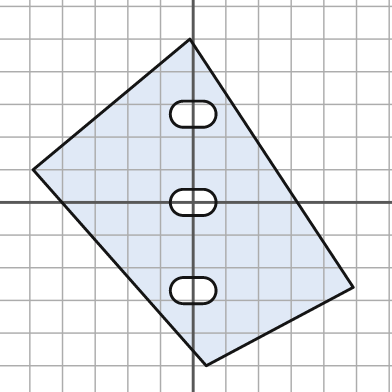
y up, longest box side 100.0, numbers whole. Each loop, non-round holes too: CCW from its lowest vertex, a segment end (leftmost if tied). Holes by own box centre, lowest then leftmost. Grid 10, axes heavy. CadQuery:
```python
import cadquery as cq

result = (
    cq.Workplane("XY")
    .moveTo(4.0, -50.0)
    .lineTo(49.0, -26.0)
    .lineTo(-1.0, 50.0)
    .lineTo(-49.0, 10.0)
    .close()
    .moveTo(-3.0, -31.0)
    .lineTo(3.0, -31.0)
    .threePointArc((7.0, -27.0), (3.0, -23.0))
    .lineTo(-3.0, -23.0)
    .threePointArc((-7.0, -27.0), (-3.0, -31.0))
    .close()
    .moveTo(-3.0, -4.0)
    .lineTo(3.0, -4.0)
    .threePointArc((7.0, 0.0), (3.0, 4.0))
    .lineTo(-3.0, 4.0)
    .threePointArc((-7.0, 0.0), (-3.0, -4.0))
    .close()
    .moveTo(-3.0, 23.0)
    .lineTo(3.0, 23.0)
    .threePointArc((7.0, 27.0), (3.0, 31.0))
    .lineTo(-3.0, 31.0)
    .threePointArc((-7.0, 27.0), (-3.0, 23.0))
    .close()
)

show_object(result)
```